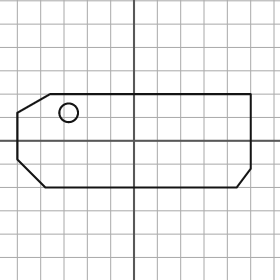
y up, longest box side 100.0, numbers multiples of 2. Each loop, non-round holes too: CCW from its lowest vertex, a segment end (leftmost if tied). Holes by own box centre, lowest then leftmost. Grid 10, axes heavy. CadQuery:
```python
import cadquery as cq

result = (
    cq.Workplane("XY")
    .moveTo(-38.0, -20.0)
    .lineTo(44.0, -20.0)
    .lineTo(50.0, -12.0)
    .lineTo(50.0, 20.0)
    .lineTo(-36.0, 20.0)
    .lineTo(-50.0, 12.0)
    .lineTo(-50.0, -8.0)
    .close()
    .moveTo(-28.0, 12.0)
    .circle(4.0)
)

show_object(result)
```